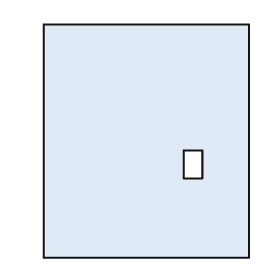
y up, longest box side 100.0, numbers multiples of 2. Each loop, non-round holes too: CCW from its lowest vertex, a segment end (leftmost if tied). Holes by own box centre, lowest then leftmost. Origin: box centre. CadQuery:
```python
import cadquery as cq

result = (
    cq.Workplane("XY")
    .moveTo(-44.0, -50.0)
    .lineTo(44.0, -50.0)
    .lineTo(44.0, 50.0)
    .lineTo(-44.0, 50.0)
    .close()
    .moveTo(16.0, -16.0)
    .lineTo(24.0, -16.0)
    .lineTo(24.0, -4.0)
    .lineTo(16.0, -4.0)
    .close()
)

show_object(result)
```